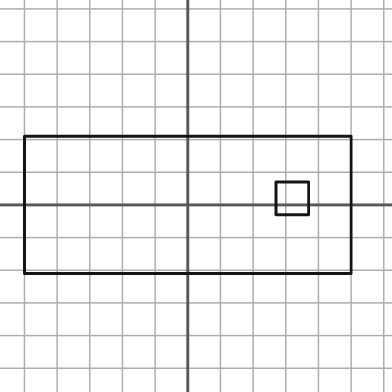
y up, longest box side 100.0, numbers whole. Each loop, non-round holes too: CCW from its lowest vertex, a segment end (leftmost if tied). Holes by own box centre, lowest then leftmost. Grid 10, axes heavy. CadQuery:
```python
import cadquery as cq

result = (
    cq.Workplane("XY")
    .moveTo(-50.0, -21.0)
    .lineTo(50.0, -21.0)
    .lineTo(50.0, 21.0)
    .lineTo(-50.0, 21.0)
    .close()
    .moveTo(27.0, -3.0)
    .lineTo(37.0, -3.0)
    .lineTo(37.0, 7.0)
    .lineTo(27.0, 7.0)
    .close()
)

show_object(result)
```